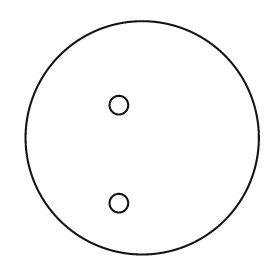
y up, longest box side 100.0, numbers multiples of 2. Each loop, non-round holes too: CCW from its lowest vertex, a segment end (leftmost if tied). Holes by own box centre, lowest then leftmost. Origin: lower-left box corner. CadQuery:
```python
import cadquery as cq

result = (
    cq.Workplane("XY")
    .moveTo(50.0, 50.0)
    .circle(50.0)
    .moveTo(40.0, 22.0)
    .circle(4.0)
    .moveTo(40.0, 64.0)
    .circle(4.0)
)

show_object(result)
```